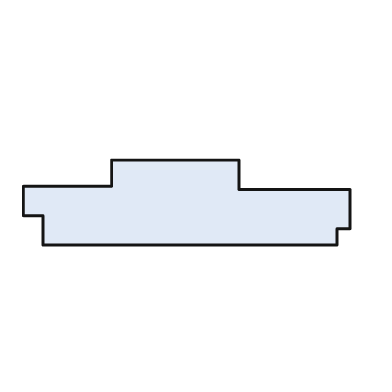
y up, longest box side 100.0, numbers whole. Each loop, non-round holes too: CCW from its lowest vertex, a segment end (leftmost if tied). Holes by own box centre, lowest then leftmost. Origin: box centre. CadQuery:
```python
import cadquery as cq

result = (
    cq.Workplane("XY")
    .moveTo(-44.0, -13.0)
    .lineTo(46.0, -13.0)
    .lineTo(46.0, -8.0)
    .lineTo(50.0, -8.0)
    .lineTo(50.0, 4.0)
    .lineTo(16.0, 4.0)
    .lineTo(16.0, 13.0)
    .lineTo(-23.0, 13.0)
    .lineTo(-23.0, 5.0)
    .lineTo(-50.0, 5.0)
    .lineTo(-50.0, -4.0)
    .lineTo(-44.0, -4.0)
    .close()
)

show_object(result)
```